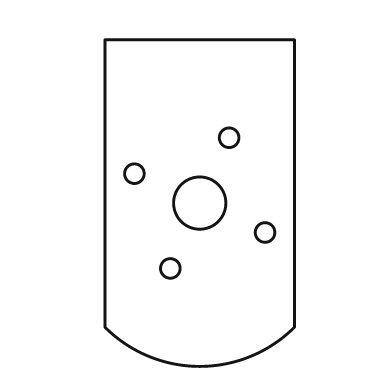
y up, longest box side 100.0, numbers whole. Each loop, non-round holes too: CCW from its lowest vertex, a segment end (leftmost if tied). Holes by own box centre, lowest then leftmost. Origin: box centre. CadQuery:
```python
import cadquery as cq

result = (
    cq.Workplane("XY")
    .moveTo(-29.0, -38.0)
    .threePointArc((0.0, -50.0), (29.0, -38.0))
    .lineTo(29.0, 50.0)
    .lineTo(-29.0, 50.0)
    .close()
    .moveTo(-9.0, -20.0)
    .circle(3.0)
    .moveTo(20.0, -9.0)
    .circle(3.0)
    .moveTo(0.0, 0.0)
    .circle(8.0)
    .moveTo(-20.0, 9.0)
    .circle(3.0)
    .moveTo(9.0, 20.0)
    .circle(3.0)
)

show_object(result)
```